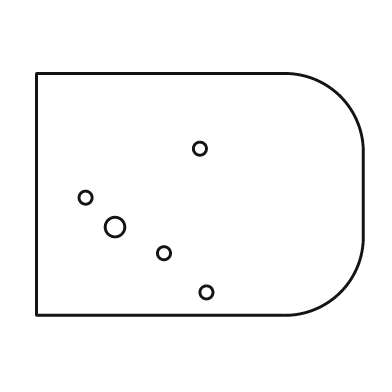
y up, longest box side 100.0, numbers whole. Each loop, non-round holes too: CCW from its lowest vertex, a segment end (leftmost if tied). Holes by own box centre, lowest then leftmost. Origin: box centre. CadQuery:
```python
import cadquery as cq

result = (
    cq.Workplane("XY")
    .moveTo(-50.0, -37.0)
    .lineTo(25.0, -37.0)
    .threePointArc((43.0, -30.0), (50.0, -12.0))
    .lineTo(50.0, 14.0)
    .threePointArc((43.0, 30.0), (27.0, 37.0))
    .lineTo(-50.0, 37.0)
    .close()
    .moveTo(2.0, -30.0)
    .circle(2.0)
    .moveTo(-11.0, -18.0)
    .circle(2.0)
    .moveTo(-26.0, -10.0)
    .circle(3.0)
    .moveTo(-35.0, -1.0)
    .circle(2.0)
    .moveTo(0.0, 14.0)
    .circle(2.0)
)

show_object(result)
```